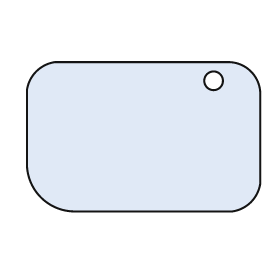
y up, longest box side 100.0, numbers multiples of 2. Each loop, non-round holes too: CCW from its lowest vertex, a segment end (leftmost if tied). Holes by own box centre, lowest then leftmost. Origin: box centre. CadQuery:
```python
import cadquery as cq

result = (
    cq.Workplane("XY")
    .moveTo(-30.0, -32.0)
    .lineTo(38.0, -32.0)
    .threePointArc((46.0, -28.0), (50.0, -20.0))
    .lineTo(50.0, 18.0)
    .threePointArc((46.0, 28.0), (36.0, 32.0))
    .lineTo(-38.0, 32.0)
    .threePointArc((-46.0, 28.0), (-50.0, 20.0))
    .lineTo(-50.0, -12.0)
    .threePointArc((-44.0, -26.0), (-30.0, -32.0))
    .close()
    .moveTo(30.0, 24.0)
    .circle(4.0)
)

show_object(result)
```